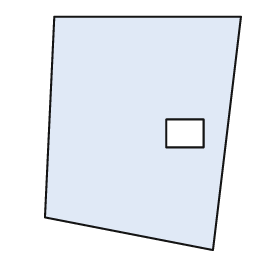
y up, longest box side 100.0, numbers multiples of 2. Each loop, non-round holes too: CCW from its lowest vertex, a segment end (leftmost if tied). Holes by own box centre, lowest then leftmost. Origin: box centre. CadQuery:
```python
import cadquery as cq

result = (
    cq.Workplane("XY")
    .moveTo(30.0, -50.0)
    .lineTo(42.0, 50.0)
    .lineTo(-38.0, 50.0)
    .lineTo(-42.0, -36.0)
    .close()
    .moveTo(10.0, -6.0)
    .lineTo(26.0, -6.0)
    .lineTo(26.0, 6.0)
    .lineTo(10.0, 6.0)
    .close()
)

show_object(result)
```